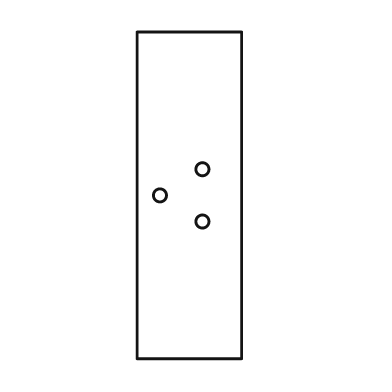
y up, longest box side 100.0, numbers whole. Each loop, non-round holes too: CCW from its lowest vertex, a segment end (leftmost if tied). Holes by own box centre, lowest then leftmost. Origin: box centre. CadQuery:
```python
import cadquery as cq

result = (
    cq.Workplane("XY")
    .moveTo(-16.0, -50.0)
    .lineTo(16.0, -50.0)
    .lineTo(16.0, 50.0)
    .lineTo(-16.0, 50.0)
    .close()
    .moveTo(4.0, -8.0)
    .circle(2.0)
    .moveTo(-9.0, 0.0)
    .circle(2.0)
    .moveTo(4.0, 8.0)
    .circle(2.0)
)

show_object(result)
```